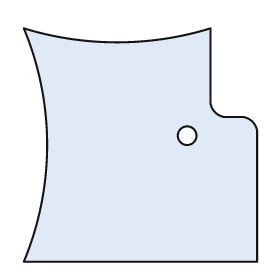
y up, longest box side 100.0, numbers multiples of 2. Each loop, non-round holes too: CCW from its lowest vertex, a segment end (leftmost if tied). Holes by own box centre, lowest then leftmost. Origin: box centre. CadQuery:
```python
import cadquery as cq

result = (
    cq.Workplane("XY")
    .moveTo(-50.0, -50.0)
    .lineTo(50.0, -50.0)
    .lineTo(50.0, 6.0)
    .threePointArc((48.0, 10.0), (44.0, 12.0))
    .lineTo(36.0, 12.0)
    .threePointArc((32.0, 14.0), (30.0, 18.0))
    .lineTo(30.0, 50.0)
    .threePointArc((-10.0, 44.0), (-50.0, 50.0))
    .threePointArc((-40.0, 0.0), (-50.0, -50.0))
    .close()
    .moveTo(20.0, 4.0)
    .circle(4.0)
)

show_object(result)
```